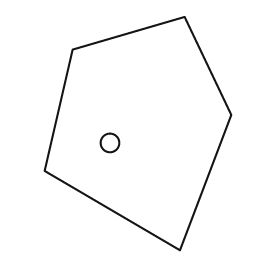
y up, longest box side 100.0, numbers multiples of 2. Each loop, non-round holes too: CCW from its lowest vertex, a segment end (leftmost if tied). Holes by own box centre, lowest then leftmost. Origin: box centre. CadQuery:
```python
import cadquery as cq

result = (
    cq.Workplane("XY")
    .moveTo(18.0, -50.0)
    .lineTo(40.0, 8.0)
    .lineTo(20.0, 50.0)
    .lineTo(-28.0, 36.0)
    .lineTo(-40.0, -16.0)
    .close()
    .moveTo(-12.0, -4.0)
    .circle(4.0)
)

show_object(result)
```